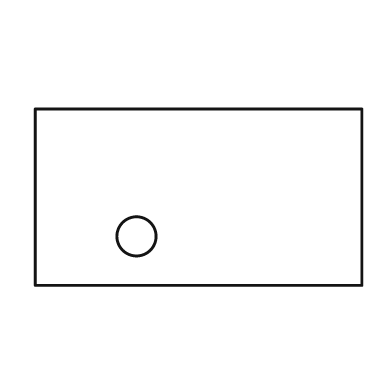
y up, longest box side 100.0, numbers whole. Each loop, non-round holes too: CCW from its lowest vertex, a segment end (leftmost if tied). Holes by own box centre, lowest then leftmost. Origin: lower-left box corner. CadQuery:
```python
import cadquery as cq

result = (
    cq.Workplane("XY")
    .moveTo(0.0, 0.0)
    .lineTo(100.0, 0.0)
    .lineTo(100.0, 54.0)
    .lineTo(0.0, 54.0)
    .close()
    .moveTo(31.0, 15.0)
    .circle(6.0)
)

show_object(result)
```